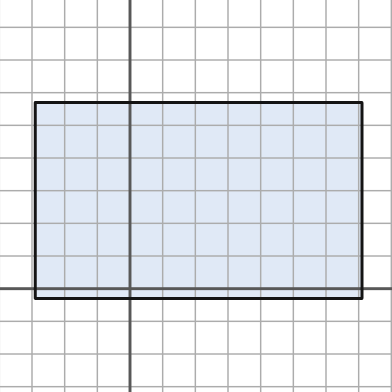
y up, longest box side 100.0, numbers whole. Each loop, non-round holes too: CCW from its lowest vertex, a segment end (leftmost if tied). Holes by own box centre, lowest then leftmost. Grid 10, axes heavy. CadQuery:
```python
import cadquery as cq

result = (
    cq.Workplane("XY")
    .moveTo(-29.0, -3.0)
    .lineTo(71.0, -3.0)
    .lineTo(71.0, 57.0)
    .lineTo(-29.0, 57.0)
    .close()
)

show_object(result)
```